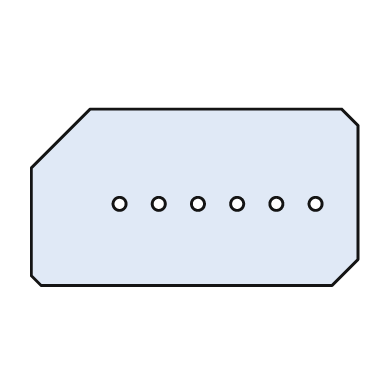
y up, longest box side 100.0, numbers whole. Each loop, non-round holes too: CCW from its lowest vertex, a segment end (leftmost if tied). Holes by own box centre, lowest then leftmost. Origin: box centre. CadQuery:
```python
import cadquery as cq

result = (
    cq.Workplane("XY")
    .moveTo(-47.0, -27.0)
    .lineTo(42.0, -27.0)
    .lineTo(50.0, -19.0)
    .lineTo(50.0, 22.0)
    .lineTo(45.0, 27.0)
    .lineTo(-32.0, 27.0)
    .lineTo(-50.0, 9.0)
    .lineTo(-50.0, -24.0)
    .close()
    .moveTo(-23.0, -2.0)
    .circle(2.0)
    .moveTo(-11.0, -2.0)
    .circle(2.0)
    .moveTo(1.0, -2.0)
    .circle(2.0)
    .moveTo(13.0, -2.0)
    .circle(2.0)
    .moveTo(25.0, -2.0)
    .circle(2.0)
    .moveTo(37.0, -2.0)
    .circle(2.0)
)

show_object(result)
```